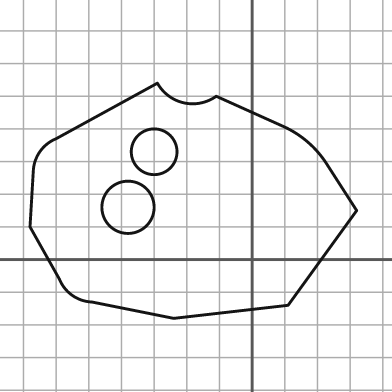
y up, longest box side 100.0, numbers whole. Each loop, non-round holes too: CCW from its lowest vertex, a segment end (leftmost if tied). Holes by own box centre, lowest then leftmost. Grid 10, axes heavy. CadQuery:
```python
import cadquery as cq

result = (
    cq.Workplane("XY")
    .moveTo(-24.0, -18.0)
    .lineTo(11.0, -14.0)
    .lineTo(32.0, 15.0)
    .lineTo(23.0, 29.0)
    .threePointArc((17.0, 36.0), (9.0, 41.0))
    .lineTo(-11.0, 50.0)
    .threePointArc((-21.0, 48.0), (-29.0, 54.0))
    .lineTo(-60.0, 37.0)
    .threePointArc((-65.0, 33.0), (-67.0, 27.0))
    .lineTo(-68.0, 10.0)
    .lineTo(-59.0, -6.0)
    .threePointArc((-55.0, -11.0), (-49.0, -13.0))
    .close()
    .moveTo(-38.0, 16.0)
    .circle(8.0)
    .moveTo(-30.0, 33.0)
    .circle(7.0)
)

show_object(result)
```